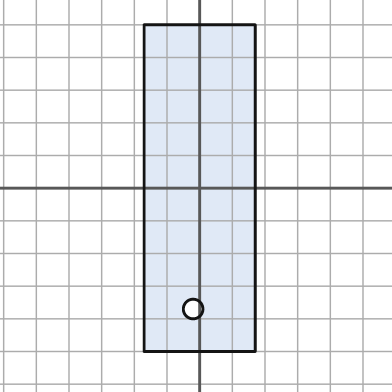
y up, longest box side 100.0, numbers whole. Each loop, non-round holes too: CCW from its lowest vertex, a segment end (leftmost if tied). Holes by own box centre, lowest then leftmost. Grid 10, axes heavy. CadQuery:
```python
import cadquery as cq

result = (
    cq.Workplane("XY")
    .moveTo(-17.0, -50.0)
    .lineTo(17.0, -50.0)
    .lineTo(17.0, 50.0)
    .lineTo(-17.0, 50.0)
    .close()
    .moveTo(-2.0, -37.0)
    .circle(3.0)
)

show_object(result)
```